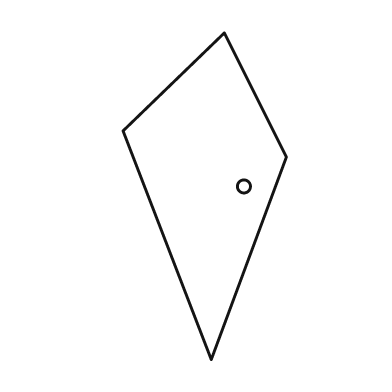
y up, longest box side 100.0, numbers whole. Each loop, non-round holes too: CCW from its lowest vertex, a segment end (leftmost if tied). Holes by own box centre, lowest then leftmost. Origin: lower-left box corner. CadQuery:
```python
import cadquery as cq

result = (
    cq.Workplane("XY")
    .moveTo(27.0, 0.0)
    .lineTo(50.0, 62.0)
    .lineTo(31.0, 100.0)
    .lineTo(0.0, 70.0)
    .close()
    .moveTo(37.0, 53.0)
    .circle(2.0)
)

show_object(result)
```